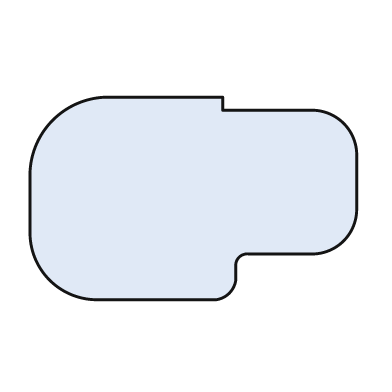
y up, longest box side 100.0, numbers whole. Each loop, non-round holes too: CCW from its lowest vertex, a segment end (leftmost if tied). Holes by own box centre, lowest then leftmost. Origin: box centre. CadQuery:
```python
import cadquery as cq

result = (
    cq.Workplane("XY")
    .moveTo(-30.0, -31.0)
    .lineTo(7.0, -31.0)
    .threePointArc((11.0, -29.0), (13.0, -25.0))
    .lineTo(13.0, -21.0)
    .threePointArc((14.0, -18.0), (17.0, -17.0))
    .lineTo(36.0, -17.0)
    .threePointArc((46.0, -13.0), (50.0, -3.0))
    .lineTo(50.0, 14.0)
    .threePointArc((46.0, 23.0), (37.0, 27.0))
    .lineTo(9.0, 27.0)
    .lineTo(9.0, 31.0)
    .lineTo(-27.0, 31.0)
    .threePointArc((-43.0, 24.0), (-50.0, 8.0))
    .lineTo(-50.0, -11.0)
    .threePointArc((-44.0, -25.0), (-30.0, -31.0))
    .close()
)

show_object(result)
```